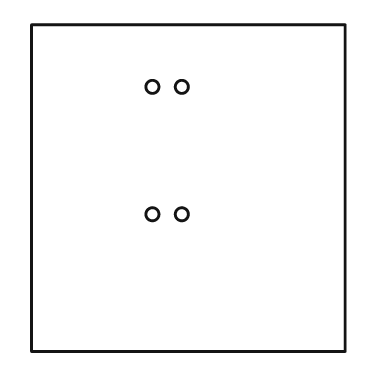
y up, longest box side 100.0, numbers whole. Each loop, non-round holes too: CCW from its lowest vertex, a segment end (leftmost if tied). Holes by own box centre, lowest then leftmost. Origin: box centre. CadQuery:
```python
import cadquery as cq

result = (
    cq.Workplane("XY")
    .moveTo(-48.0, -50.0)
    .lineTo(48.0, -50.0)
    .lineTo(48.0, 50.0)
    .lineTo(-48.0, 50.0)
    .close()
    .moveTo(-11.0, -8.0)
    .circle(2.0)
    .moveTo(-2.0, -8.0)
    .circle(2.0)
    .moveTo(-11.0, 31.0)
    .circle(2.0)
    .moveTo(-2.0, 31.0)
    .circle(2.0)
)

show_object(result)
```